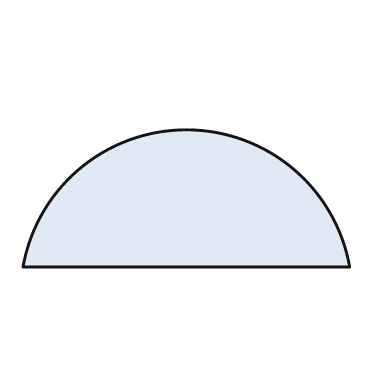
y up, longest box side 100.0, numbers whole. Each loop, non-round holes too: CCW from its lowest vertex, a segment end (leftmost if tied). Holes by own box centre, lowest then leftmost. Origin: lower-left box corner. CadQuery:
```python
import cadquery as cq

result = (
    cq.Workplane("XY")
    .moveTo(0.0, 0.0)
    .lineTo(100.0, 0.0)
    .threePointArc((50.0, 42.0), (0.0, 0.0))
    .close()
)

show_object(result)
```